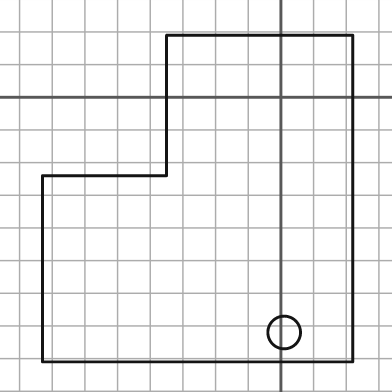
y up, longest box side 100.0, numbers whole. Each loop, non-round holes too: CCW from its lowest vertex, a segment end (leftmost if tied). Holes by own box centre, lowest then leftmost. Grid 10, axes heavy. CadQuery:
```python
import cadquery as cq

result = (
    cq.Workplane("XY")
    .moveTo(-73.0, -81.0)
    .lineTo(22.0, -81.0)
    .lineTo(22.0, 19.0)
    .lineTo(-35.0, 19.0)
    .lineTo(-35.0, -24.0)
    .lineTo(-73.0, -24.0)
    .close()
    .moveTo(1.0, -72.0)
    .circle(5.0)
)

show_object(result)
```